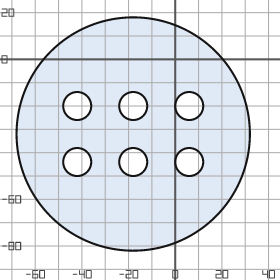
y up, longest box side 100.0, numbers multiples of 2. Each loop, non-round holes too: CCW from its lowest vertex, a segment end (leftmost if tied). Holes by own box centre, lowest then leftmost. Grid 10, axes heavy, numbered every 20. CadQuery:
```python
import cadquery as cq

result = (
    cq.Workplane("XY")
    .moveTo(-18.0, -32.0)
    .circle(50.0)
    .moveTo(-42.0, -44.0)
    .circle(6.0)
    .moveTo(-18.0, -44.0)
    .circle(6.0)
    .moveTo(6.0, -44.0)
    .circle(6.0)
    .moveTo(-42.0, -20.0)
    .circle(6.0)
    .moveTo(-18.0, -20.0)
    .circle(6.0)
    .moveTo(6.0, -20.0)
    .circle(6.0)
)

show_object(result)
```